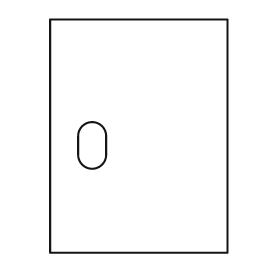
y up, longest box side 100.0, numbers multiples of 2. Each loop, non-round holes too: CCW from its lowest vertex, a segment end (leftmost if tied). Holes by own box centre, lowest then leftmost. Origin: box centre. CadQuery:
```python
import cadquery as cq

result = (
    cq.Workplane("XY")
    .moveTo(-38.0, -50.0)
    .lineTo(38.0, -50.0)
    .lineTo(38.0, 50.0)
    .lineTo(-38.0, 50.0)
    .close()
    .moveTo(-26.0, -8.0)
    .threePointArc((-20.0, -14.0), (-14.0, -8.0))
    .lineTo(-14.0, 0.0)
    .threePointArc((-20.0, 6.0), (-26.0, 0.0))
    .close()
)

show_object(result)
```